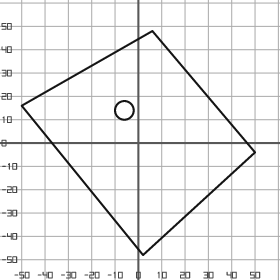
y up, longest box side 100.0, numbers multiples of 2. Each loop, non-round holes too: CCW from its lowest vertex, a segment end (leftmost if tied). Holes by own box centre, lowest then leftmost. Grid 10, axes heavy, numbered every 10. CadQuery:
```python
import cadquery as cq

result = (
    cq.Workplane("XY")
    .moveTo(2.0, -48.0)
    .lineTo(50.0, -4.0)
    .lineTo(6.0, 48.0)
    .lineTo(-50.0, 16.0)
    .close()
    .moveTo(-6.0, 14.0)
    .circle(4.0)
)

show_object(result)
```